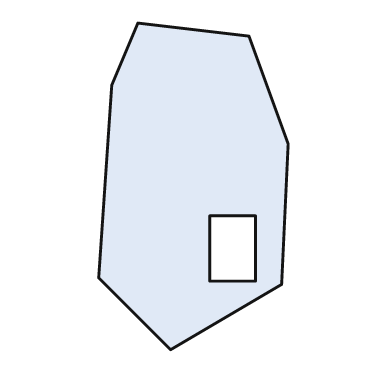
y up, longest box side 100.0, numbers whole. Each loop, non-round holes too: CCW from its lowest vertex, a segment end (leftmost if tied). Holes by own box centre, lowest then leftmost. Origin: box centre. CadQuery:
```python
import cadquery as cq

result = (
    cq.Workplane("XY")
    .moveTo(-7.0, -50.0)
    .lineTo(27.0, -30.0)
    .lineTo(29.0, 13.0)
    .lineTo(17.0, 46.0)
    .lineTo(-17.0, 50.0)
    .lineTo(-25.0, 31.0)
    .lineTo(-29.0, -28.0)
    .close()
    .moveTo(5.0, -29.0)
    .lineTo(19.0, -29.0)
    .lineTo(19.0, -9.0)
    .lineTo(5.0, -9.0)
    .close()
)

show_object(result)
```